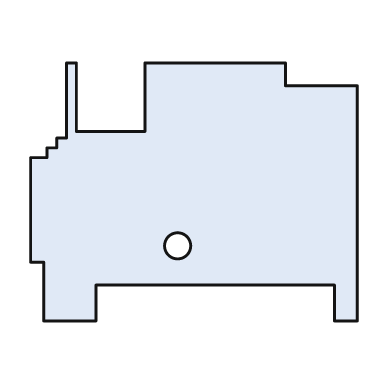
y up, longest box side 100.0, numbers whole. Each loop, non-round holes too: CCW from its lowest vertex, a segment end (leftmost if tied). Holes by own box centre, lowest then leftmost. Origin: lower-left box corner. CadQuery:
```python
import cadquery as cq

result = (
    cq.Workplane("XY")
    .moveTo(4.0, 0.0)
    .lineTo(20.0, 0.0)
    .lineTo(20.0, 11.0)
    .lineTo(93.0, 11.0)
    .lineTo(93.0, 0.0)
    .lineTo(100.0, 0.0)
    .lineTo(100.0, 72.0)
    .lineTo(78.0, 72.0)
    .lineTo(78.0, 79.0)
    .lineTo(35.0, 79.0)
    .lineTo(35.0, 58.0)
    .lineTo(14.0, 58.0)
    .lineTo(14.0, 79.0)
    .lineTo(11.0, 79.0)
    .lineTo(11.0, 56.0)
    .lineTo(8.0, 56.0)
    .lineTo(8.0, 53.0)
    .lineTo(5.0, 53.0)
    .lineTo(5.0, 50.0)
    .lineTo(0.0, 50.0)
    .lineTo(0.0, 18.0)
    .lineTo(4.0, 18.0)
    .close()
    .moveTo(45.0, 23.0)
    .circle(4.0)
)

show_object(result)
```